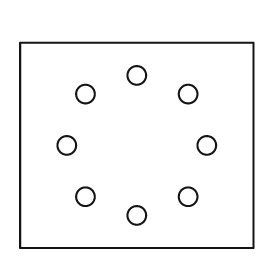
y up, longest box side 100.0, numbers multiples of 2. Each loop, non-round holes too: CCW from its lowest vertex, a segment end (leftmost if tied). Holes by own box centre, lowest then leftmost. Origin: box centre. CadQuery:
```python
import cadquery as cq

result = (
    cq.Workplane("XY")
    .moveTo(-50.0, -44.0)
    .lineTo(50.0, -44.0)
    .lineTo(50.0, 44.0)
    .lineTo(-50.0, 44.0)
    .close()
    .moveTo(0.0, -30.0)
    .circle(4.0)
    .moveTo(-22.0, -22.0)
    .circle(4.0)
    .moveTo(22.0, -22.0)
    .circle(4.0)
    .moveTo(-30.0, 0.0)
    .circle(4.0)
    .moveTo(30.0, 0.0)
    .circle(4.0)
    .moveTo(-22.0, 22.0)
    .circle(4.0)
    .moveTo(22.0, 22.0)
    .circle(4.0)
    .moveTo(0.0, 30.0)
    .circle(4.0)
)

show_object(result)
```